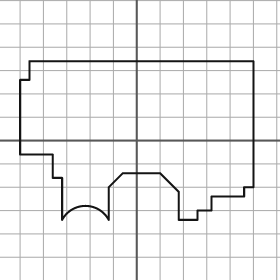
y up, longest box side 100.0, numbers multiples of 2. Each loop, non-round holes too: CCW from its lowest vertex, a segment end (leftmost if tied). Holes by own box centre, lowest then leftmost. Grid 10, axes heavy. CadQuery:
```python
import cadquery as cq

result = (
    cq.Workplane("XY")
    .moveTo(-32.0, -34.0)
    .threePointArc((-22.0, -28.0), (-12.0, -34.0))
    .lineTo(-12.0, -20.0)
    .lineTo(-6.0, -14.0)
    .lineTo(10.0, -14.0)
    .lineTo(18.0, -22.0)
    .lineTo(18.0, -34.0)
    .lineTo(26.0, -34.0)
    .lineTo(26.0, -30.0)
    .lineTo(32.0, -30.0)
    .lineTo(32.0, -24.0)
    .lineTo(46.0, -24.0)
    .lineTo(46.0, -20.0)
    .lineTo(50.0, -20.0)
    .lineTo(50.0, 34.0)
    .lineTo(-46.0, 34.0)
    .lineTo(-46.0, 26.0)
    .lineTo(-50.0, 26.0)
    .lineTo(-50.0, -6.0)
    .lineTo(-36.0, -6.0)
    .lineTo(-36.0, -16.0)
    .lineTo(-32.0, -16.0)
    .close()
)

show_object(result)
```